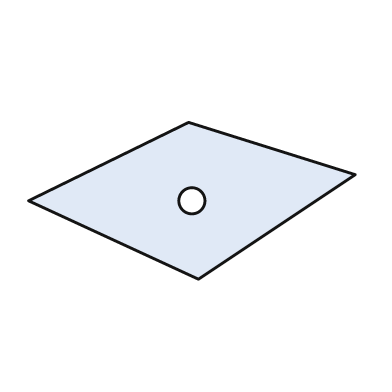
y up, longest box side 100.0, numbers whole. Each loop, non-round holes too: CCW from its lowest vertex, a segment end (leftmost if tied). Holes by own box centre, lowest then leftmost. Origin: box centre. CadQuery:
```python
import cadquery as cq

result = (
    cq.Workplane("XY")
    .moveTo(2.0, -24.0)
    .lineTo(50.0, 8.0)
    .lineTo(-1.0, 24.0)
    .lineTo(-50.0, 0.0)
    .close()
    .moveTo(0.0, 0.0)
    .circle(4.0)
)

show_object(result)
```